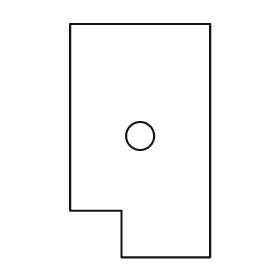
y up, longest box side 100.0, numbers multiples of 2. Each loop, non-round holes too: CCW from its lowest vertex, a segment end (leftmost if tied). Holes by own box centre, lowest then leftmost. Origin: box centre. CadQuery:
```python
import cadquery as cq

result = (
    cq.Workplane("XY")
    .moveTo(-8.0, -50.0)
    .lineTo(30.0, -50.0)
    .lineTo(30.0, 50.0)
    .lineTo(-30.0, 50.0)
    .lineTo(-30.0, -30.0)
    .lineTo(-8.0, -30.0)
    .close()
    .moveTo(0.0, 2.0)
    .circle(6.0)
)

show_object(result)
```